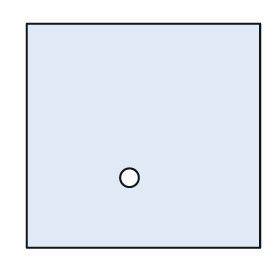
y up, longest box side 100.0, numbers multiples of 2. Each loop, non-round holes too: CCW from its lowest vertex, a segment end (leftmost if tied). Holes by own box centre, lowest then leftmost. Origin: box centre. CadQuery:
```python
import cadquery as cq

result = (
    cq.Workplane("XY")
    .moveTo(-50.0, -48.0)
    .lineTo(50.0, -48.0)
    .lineTo(50.0, 48.0)
    .lineTo(-50.0, 48.0)
    .close()
    .moveTo(-6.0, -18.0)
    .circle(4.0)
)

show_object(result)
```